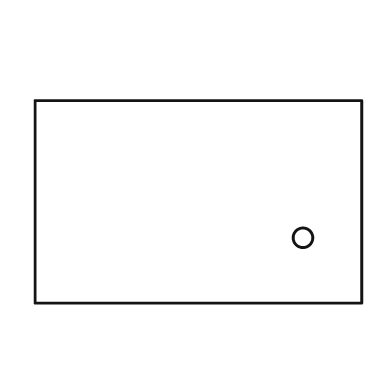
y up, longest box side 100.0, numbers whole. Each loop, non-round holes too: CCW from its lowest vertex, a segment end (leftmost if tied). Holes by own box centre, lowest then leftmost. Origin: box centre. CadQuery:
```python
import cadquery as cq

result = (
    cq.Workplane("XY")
    .moveTo(-50.0, -31.0)
    .lineTo(50.0, -31.0)
    .lineTo(50.0, 31.0)
    .lineTo(-50.0, 31.0)
    .close()
    .moveTo(32.0, -11.0)
    .circle(3.0)
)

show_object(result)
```